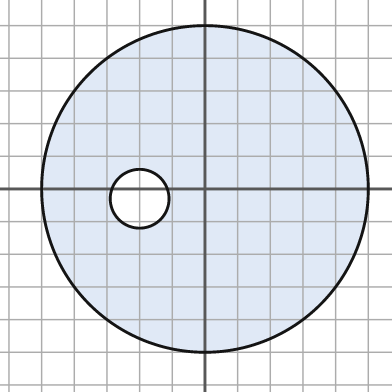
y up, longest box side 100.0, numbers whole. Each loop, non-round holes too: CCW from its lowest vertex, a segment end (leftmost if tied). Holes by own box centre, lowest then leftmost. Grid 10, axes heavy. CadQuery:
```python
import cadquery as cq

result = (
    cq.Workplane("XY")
    .moveTo(0.0, 0.0)
    .circle(50.0)
    .moveTo(-20.0, -3.0)
    .circle(9.0)
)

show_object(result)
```